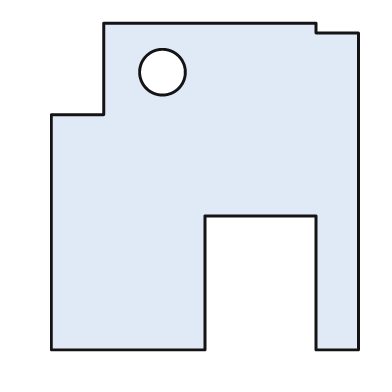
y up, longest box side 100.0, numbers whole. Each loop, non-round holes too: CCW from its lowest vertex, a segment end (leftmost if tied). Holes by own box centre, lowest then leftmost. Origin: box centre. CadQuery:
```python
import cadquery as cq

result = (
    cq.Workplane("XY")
    .moveTo(-47.0, -50.0)
    .lineTo(0.0, -50.0)
    .lineTo(0.0, -9.0)
    .lineTo(34.0, -9.0)
    .lineTo(34.0, -50.0)
    .lineTo(47.0, -50.0)
    .lineTo(47.0, 47.0)
    .lineTo(34.0, 47.0)
    .lineTo(34.0, 50.0)
    .lineTo(-31.0, 50.0)
    .lineTo(-31.0, 22.0)
    .lineTo(-47.0, 22.0)
    .close()
    .moveTo(-13.0, 35.0)
    .circle(7.0)
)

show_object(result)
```